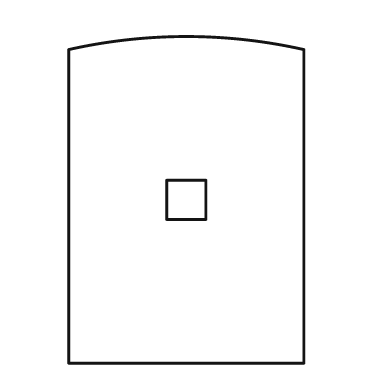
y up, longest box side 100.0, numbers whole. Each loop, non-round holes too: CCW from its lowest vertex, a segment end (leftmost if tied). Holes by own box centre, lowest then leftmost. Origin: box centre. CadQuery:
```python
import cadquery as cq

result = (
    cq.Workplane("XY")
    .moveTo(-36.0, -50.0)
    .lineTo(36.0, -50.0)
    .lineTo(36.0, 46.0)
    .threePointArc((0.0, 50.0), (-36.0, 46.0))
    .close()
    .moveTo(-6.0, -6.0)
    .lineTo(6.0, -6.0)
    .lineTo(6.0, 6.0)
    .lineTo(-6.0, 6.0)
    .close()
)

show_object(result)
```